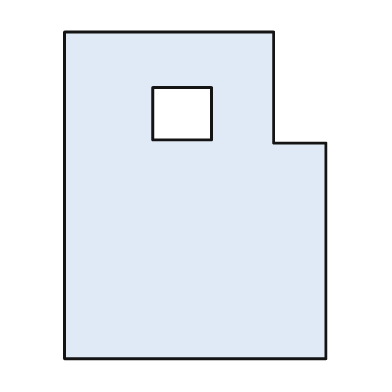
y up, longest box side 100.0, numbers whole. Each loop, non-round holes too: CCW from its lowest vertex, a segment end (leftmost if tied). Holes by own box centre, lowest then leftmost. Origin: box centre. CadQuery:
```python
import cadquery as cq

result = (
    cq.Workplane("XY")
    .moveTo(-40.0, -50.0)
    .lineTo(40.0, -50.0)
    .lineTo(40.0, 16.0)
    .lineTo(24.0, 16.0)
    .lineTo(24.0, 50.0)
    .lineTo(-40.0, 50.0)
    .close()
    .moveTo(-13.0, 17.0)
    .lineTo(5.0, 17.0)
    .lineTo(5.0, 33.0)
    .lineTo(-13.0, 33.0)
    .close()
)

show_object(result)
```